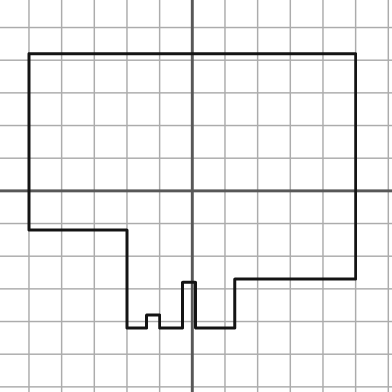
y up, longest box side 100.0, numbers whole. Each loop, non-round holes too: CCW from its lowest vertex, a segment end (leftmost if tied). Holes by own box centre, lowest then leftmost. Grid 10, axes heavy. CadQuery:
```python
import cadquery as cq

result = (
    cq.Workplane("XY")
    .moveTo(-20.0, -42.0)
    .lineTo(-14.0, -42.0)
    .lineTo(-14.0, -38.0)
    .lineTo(-10.0, -38.0)
    .lineTo(-10.0, -42.0)
    .lineTo(-3.0, -42.0)
    .lineTo(-3.0, -28.0)
    .lineTo(1.0, -28.0)
    .lineTo(1.0, -42.0)
    .lineTo(13.0, -42.0)
    .lineTo(13.0, -27.0)
    .lineTo(50.0, -27.0)
    .lineTo(50.0, 42.0)
    .lineTo(-50.0, 42.0)
    .lineTo(-50.0, -12.0)
    .lineTo(-20.0, -12.0)
    .close()
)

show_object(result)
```